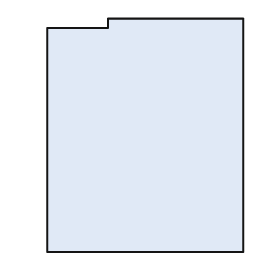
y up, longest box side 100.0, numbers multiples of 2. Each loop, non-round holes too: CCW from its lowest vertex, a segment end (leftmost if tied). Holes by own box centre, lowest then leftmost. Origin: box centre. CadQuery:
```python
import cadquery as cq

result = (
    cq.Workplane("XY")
    .moveTo(-42.0, -50.0)
    .lineTo(42.0, -50.0)
    .lineTo(42.0, 50.0)
    .lineTo(-16.0, 50.0)
    .lineTo(-16.0, 46.0)
    .lineTo(-42.0, 46.0)
    .close()
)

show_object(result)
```